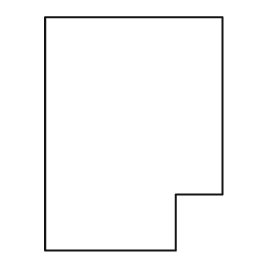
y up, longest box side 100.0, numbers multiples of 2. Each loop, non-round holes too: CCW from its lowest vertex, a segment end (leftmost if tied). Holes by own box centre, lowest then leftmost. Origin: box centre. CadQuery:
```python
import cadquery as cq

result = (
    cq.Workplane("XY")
    .moveTo(-38.0, -50.0)
    .lineTo(18.0, -50.0)
    .lineTo(18.0, -26.0)
    .lineTo(38.0, -26.0)
    .lineTo(38.0, 50.0)
    .lineTo(-38.0, 50.0)
    .close()
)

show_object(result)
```